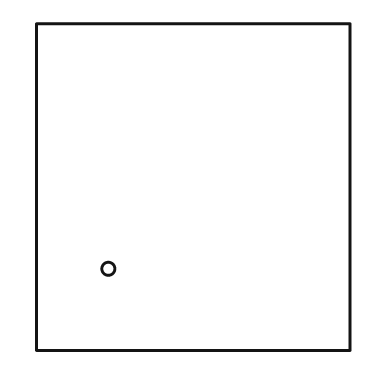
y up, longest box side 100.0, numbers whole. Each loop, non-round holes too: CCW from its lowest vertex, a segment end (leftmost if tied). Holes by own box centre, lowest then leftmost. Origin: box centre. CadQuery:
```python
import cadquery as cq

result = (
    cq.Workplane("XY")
    .moveTo(-48.0, -50.0)
    .lineTo(48.0, -50.0)
    .lineTo(48.0, 50.0)
    .lineTo(-48.0, 50.0)
    .close()
    .moveTo(-26.0, -25.0)
    .circle(2.0)
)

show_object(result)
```